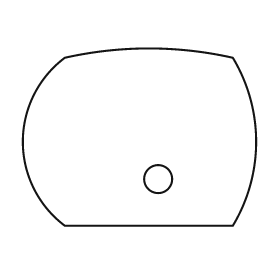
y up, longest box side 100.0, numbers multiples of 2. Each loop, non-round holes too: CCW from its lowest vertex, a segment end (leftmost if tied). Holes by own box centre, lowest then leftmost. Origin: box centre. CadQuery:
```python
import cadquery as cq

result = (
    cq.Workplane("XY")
    .moveTo(-32.0, -38.0)
    .lineTo(40.0, -38.0)
    .threePointArc((50.0, -2.0), (40.0, 34.0))
    .threePointArc((4.0, 38.0), (-32.0, 34.0))
    .threePointArc((-50.0, -2.0), (-32.0, -38.0))
    .close()
    .moveTo(8.0, -18.0)
    .circle(6.0)
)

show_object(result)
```